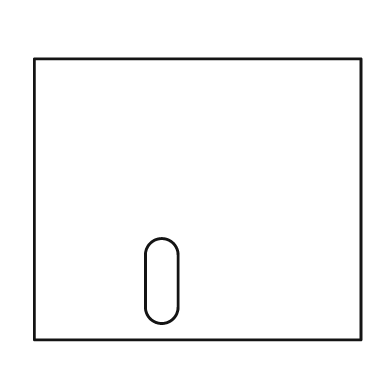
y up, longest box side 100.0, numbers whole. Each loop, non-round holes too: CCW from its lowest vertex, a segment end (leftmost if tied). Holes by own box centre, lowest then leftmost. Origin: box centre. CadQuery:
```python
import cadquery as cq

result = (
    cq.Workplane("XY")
    .moveTo(-50.0, -43.0)
    .lineTo(50.0, -43.0)
    .lineTo(50.0, 43.0)
    .lineTo(-50.0, 43.0)
    .close()
    .moveTo(-16.0, -33.0)
    .threePointArc((-11.0, -38.0), (-6.0, -33.0))
    .lineTo(-6.0, -17.0)
    .threePointArc((-11.0, -12.0), (-16.0, -17.0))
    .close()
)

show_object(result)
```